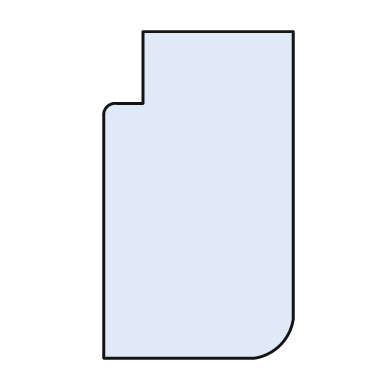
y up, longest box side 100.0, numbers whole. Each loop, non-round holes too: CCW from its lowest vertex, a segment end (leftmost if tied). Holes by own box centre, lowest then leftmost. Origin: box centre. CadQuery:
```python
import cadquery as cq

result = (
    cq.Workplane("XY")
    .moveTo(-29.0, -50.0)
    .lineTo(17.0, -50.0)
    .threePointArc((25.0, -46.0), (29.0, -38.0))
    .lineTo(29.0, 50.0)
    .lineTo(-17.0, 50.0)
    .lineTo(-17.0, 28.0)
    .lineTo(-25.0, 28.0)
    .threePointArc((-28.0, 27.0), (-29.0, 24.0))
    .close()
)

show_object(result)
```